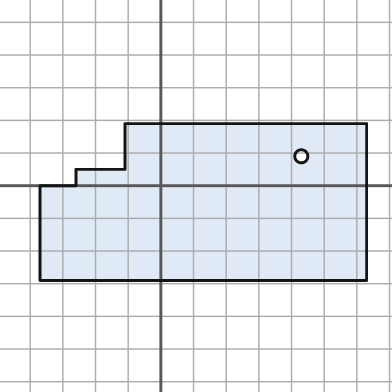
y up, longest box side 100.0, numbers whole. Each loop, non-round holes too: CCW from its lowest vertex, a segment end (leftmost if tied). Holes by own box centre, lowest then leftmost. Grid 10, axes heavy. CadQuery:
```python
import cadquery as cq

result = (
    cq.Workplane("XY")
    .moveTo(-37.0, -29.0)
    .lineTo(63.0, -29.0)
    .lineTo(63.0, 19.0)
    .lineTo(-11.0, 19.0)
    .lineTo(-11.0, 5.0)
    .lineTo(-26.0, 5.0)
    .lineTo(-26.0, 0.0)
    .lineTo(-37.0, 0.0)
    .close()
    .moveTo(43.0, 9.0)
    .circle(2.0)
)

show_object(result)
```